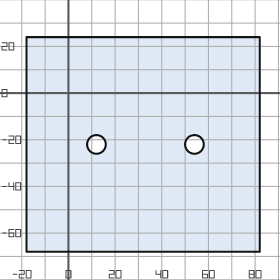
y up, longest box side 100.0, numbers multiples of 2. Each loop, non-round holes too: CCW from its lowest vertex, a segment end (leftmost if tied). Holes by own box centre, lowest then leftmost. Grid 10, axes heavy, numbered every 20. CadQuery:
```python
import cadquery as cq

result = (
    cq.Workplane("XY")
    .moveTo(-18.0, -68.0)
    .lineTo(82.0, -68.0)
    .lineTo(82.0, 24.0)
    .lineTo(-18.0, 24.0)
    .close()
    .moveTo(12.0, -22.0)
    .circle(4.0)
    .moveTo(54.0, -22.0)
    .circle(4.0)
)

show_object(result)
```